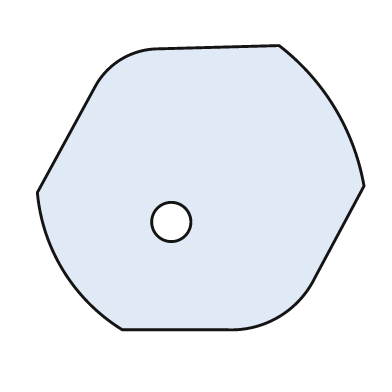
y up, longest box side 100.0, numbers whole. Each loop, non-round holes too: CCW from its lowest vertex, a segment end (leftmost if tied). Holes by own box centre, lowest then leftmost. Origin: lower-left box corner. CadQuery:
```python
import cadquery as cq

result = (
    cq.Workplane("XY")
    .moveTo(26.0, 0.0)
    .lineTo(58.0, 0.0)
    .threePointArc((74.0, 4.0), (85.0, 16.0))
    .lineTo(100.0, 44.0)
    .threePointArc((91.0, 68.0), (74.0, 87.0))
    .lineTo(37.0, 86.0)
    .threePointArc((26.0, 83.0), (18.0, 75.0))
    .lineTo(0.0, 42.0)
    .threePointArc((8.0, 18.0), (26.0, 0.0))
    .close()
    .moveTo(41.0, 33.0)
    .circle(6.0)
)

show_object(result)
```